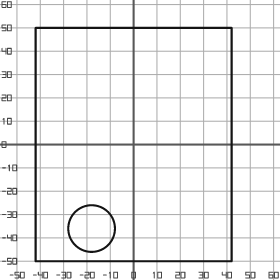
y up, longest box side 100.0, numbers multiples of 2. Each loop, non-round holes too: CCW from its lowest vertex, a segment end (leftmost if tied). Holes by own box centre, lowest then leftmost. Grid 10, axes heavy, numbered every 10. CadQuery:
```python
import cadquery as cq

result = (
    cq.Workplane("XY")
    .moveTo(-42.0, -50.0)
    .lineTo(42.0, -50.0)
    .lineTo(42.0, 50.0)
    .lineTo(-42.0, 50.0)
    .close()
    .moveTo(-18.0, -36.0)
    .circle(10.0)
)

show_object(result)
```